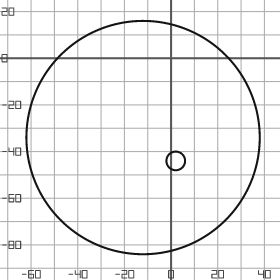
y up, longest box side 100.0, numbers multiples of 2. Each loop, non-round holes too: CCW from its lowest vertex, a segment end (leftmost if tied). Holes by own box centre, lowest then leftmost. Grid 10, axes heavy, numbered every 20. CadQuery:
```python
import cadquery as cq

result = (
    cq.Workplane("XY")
    .moveTo(-12.0, -34.0)
    .circle(50.0)
    .moveTo(2.0, -44.0)
    .circle(4.0)
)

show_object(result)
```